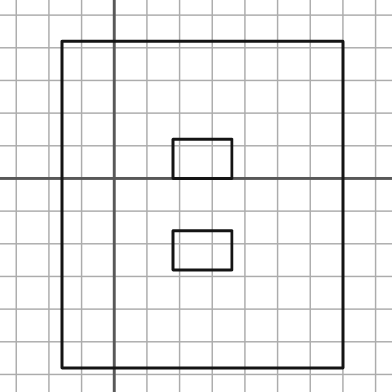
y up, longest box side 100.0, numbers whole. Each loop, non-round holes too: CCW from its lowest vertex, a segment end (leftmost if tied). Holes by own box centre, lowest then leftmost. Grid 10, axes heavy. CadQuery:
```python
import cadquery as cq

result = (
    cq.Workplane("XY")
    .moveTo(-16.0, -58.0)
    .lineTo(70.0, -58.0)
    .lineTo(70.0, 42.0)
    .lineTo(-16.0, 42.0)
    .close()
    .moveTo(18.0, -28.0)
    .lineTo(36.0, -28.0)
    .lineTo(36.0, -16.0)
    .lineTo(18.0, -16.0)
    .close()
    .moveTo(18.0, 0.0)
    .lineTo(36.0, 0.0)
    .lineTo(36.0, 12.0)
    .lineTo(18.0, 12.0)
    .close()
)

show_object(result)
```